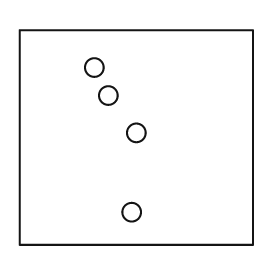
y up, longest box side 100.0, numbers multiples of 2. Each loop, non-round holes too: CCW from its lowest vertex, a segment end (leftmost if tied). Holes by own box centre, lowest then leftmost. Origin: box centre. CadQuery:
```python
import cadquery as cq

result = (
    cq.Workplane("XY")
    .moveTo(-50.0, -46.0)
    .lineTo(50.0, -46.0)
    .lineTo(50.0, 46.0)
    .lineTo(-50.0, 46.0)
    .close()
    .moveTo(-2.0, -32.0)
    .circle(4.0)
    .moveTo(0.0, 2.0)
    .circle(4.0)
    .moveTo(-12.0, 18.0)
    .circle(4.0)
    .moveTo(-18.0, 30.0)
    .circle(4.0)
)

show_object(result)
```